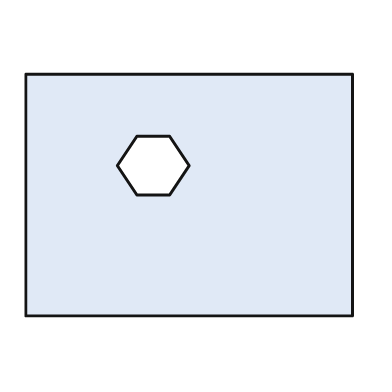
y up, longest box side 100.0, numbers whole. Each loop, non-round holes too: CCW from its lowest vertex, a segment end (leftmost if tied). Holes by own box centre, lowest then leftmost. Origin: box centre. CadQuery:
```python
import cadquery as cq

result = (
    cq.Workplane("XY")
    .moveTo(-50.0, -37.0)
    .lineTo(50.0, -37.0)
    .lineTo(50.0, 37.0)
    .lineTo(-50.0, 37.0)
    .close()
    .moveTo(-16.0, 0.0)
    .lineTo(-6.0, 0.0)
    .lineTo(0.0, 9.0)
    .lineTo(-6.0, 18.0)
    .lineTo(-16.0, 18.0)
    .lineTo(-22.0, 9.0)
    .close()
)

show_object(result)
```